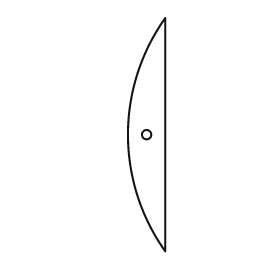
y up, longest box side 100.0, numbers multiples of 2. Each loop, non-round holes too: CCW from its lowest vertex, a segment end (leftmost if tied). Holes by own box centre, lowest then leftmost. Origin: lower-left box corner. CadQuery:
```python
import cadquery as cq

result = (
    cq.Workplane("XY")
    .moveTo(16.0, 0.0)
    .lineTo(16.0, 100.0)
    .threePointArc((0.0, 50.0), (16.0, 0.0))
    .close()
    .moveTo(8.0, 50.0)
    .circle(2.0)
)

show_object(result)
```